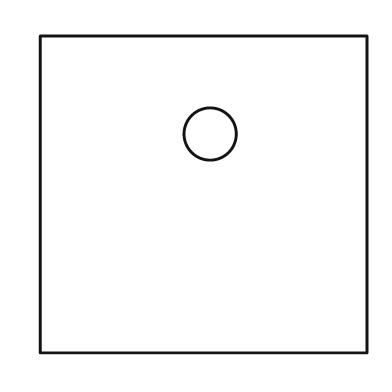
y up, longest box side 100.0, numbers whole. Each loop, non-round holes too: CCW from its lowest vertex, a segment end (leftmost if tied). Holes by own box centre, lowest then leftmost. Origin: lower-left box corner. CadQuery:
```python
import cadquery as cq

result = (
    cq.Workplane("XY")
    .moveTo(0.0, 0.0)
    .lineTo(100.0, 0.0)
    .lineTo(100.0, 97.0)
    .lineTo(0.0, 97.0)
    .close()
    .moveTo(52.0, 67.0)
    .circle(8.0)
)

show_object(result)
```